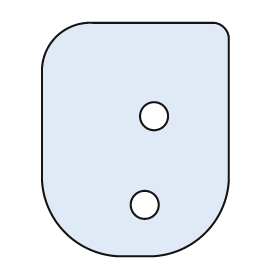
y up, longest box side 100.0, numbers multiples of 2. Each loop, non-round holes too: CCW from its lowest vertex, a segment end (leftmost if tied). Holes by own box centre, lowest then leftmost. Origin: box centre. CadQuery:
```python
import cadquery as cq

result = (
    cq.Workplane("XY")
    .moveTo(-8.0, -50.0)
    .lineTo(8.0, -50.0)
    .threePointArc((30.0, -40.0), (40.0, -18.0))
    .lineTo(40.0, 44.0)
    .threePointArc((38.0, 48.0), (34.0, 50.0))
    .lineTo(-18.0, 50.0)
    .threePointArc((-34.0, 44.0), (-40.0, 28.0))
    .lineTo(-40.0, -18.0)
    .threePointArc((-30.0, -40.0), (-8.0, -50.0))
    .close()
    .moveTo(4.0, -28.0)
    .circle(6.0)
    .moveTo(8.0, 10.0)
    .circle(6.0)
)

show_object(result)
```